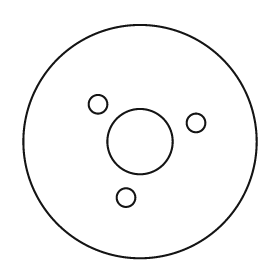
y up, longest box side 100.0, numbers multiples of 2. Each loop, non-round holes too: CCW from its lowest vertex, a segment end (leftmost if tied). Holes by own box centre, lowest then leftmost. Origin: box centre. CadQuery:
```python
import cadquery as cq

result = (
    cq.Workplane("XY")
    .moveTo(0.0, 0.0)
    .circle(50.0)
    .moveTo(-6.0, -24.0)
    .circle(4.0)
    .moveTo(0.0, 0.0)
    .circle(14.0)
    .moveTo(24.0, 8.0)
    .circle(4.0)
    .moveTo(-18.0, 16.0)
    .circle(4.0)
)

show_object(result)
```